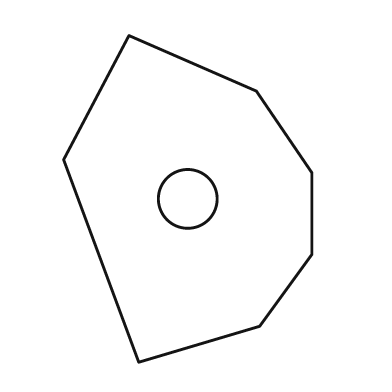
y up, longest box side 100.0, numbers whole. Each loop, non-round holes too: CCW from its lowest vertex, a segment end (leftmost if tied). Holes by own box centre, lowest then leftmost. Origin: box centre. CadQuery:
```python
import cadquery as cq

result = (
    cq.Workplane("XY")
    .moveTo(-15.0, -50.0)
    .lineTo(22.0, -39.0)
    .lineTo(38.0, -17.0)
    .lineTo(38.0, 8.0)
    .lineTo(21.0, 33.0)
    .lineTo(-18.0, 50.0)
    .lineTo(-38.0, 12.0)
    .close()
    .moveTo(0.0, 0.0)
    .circle(9.0)
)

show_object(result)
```